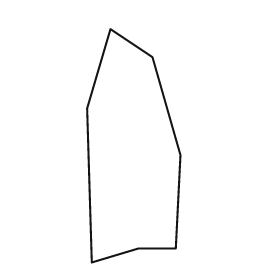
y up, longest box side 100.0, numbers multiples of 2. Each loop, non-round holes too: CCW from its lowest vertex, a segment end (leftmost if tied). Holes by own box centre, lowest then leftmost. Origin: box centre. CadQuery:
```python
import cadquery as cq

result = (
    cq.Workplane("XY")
    .moveTo(-18.0, -50.0)
    .lineTo(2.0, -44.0)
    .lineTo(18.0, -44.0)
    .lineTo(20.0, -4.0)
    .lineTo(8.0, 38.0)
    .lineTo(-10.0, 50.0)
    .lineTo(-20.0, 16.0)
    .close()
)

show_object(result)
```